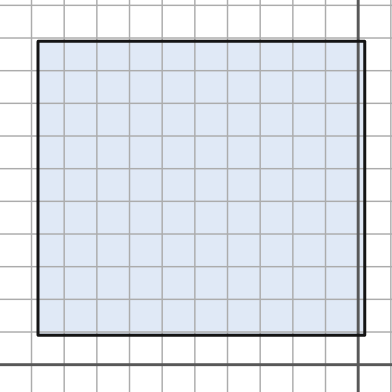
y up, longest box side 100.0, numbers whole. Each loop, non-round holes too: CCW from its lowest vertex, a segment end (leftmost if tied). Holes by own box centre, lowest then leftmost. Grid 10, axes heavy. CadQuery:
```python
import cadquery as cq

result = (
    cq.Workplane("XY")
    .moveTo(-98.0, 9.0)
    .lineTo(2.0, 9.0)
    .lineTo(2.0, 99.0)
    .lineTo(-98.0, 99.0)
    .close()
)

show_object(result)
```